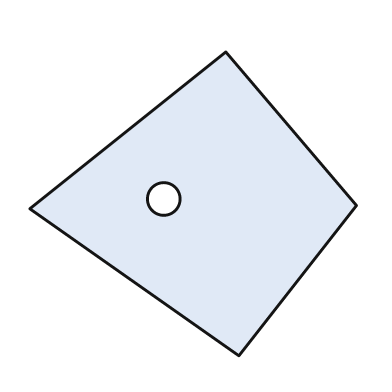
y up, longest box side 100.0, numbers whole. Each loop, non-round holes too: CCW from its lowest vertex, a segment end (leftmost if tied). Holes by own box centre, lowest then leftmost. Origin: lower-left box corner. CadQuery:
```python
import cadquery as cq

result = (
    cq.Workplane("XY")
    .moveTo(64.0, 0.0)
    .lineTo(100.0, 46.0)
    .lineTo(60.0, 93.0)
    .lineTo(0.0, 45.0)
    .close()
    .moveTo(41.0, 48.0)
    .circle(5.0)
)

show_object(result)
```